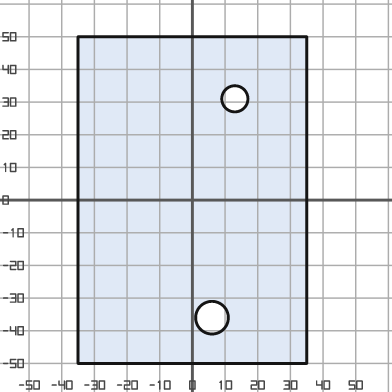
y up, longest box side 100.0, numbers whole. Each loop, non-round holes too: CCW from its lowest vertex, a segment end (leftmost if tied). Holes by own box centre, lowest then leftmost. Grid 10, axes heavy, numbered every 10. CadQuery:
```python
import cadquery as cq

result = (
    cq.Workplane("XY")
    .moveTo(-35.0, -50.0)
    .lineTo(35.0, -50.0)
    .lineTo(35.0, 50.0)
    .lineTo(-35.0, 50.0)
    .close()
    .moveTo(6.0, -36.0)
    .circle(5.0)
    .moveTo(13.0, 31.0)
    .circle(4.0)
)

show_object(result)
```